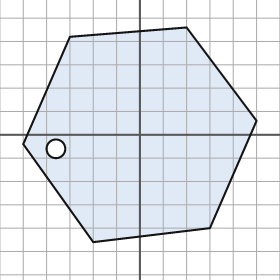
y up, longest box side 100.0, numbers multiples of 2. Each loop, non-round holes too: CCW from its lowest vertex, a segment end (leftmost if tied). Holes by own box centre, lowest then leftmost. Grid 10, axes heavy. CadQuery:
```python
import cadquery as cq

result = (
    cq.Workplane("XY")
    .moveTo(-20.0, -46.0)
    .lineTo(30.0, -40.0)
    .lineTo(50.0, 6.0)
    .lineTo(20.0, 46.0)
    .lineTo(-30.0, 42.0)
    .lineTo(-50.0, -4.0)
    .close()
    .moveTo(-36.0, -6.0)
    .circle(4.0)
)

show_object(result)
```